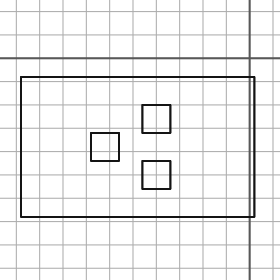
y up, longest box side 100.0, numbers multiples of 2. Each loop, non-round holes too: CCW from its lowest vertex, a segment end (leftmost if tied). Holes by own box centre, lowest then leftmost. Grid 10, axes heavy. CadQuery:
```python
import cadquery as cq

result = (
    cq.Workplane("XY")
    .moveTo(-98.0, -68.0)
    .lineTo(2.0, -68.0)
    .lineTo(2.0, -8.0)
    .lineTo(-98.0, -8.0)
    .close()
    .moveTo(-46.0, -56.0)
    .lineTo(-34.0, -56.0)
    .lineTo(-34.0, -44.0)
    .lineTo(-46.0, -44.0)
    .close()
    .moveTo(-68.0, -44.0)
    .lineTo(-56.0, -44.0)
    .lineTo(-56.0, -32.0)
    .lineTo(-68.0, -32.0)
    .close()
    .moveTo(-46.0, -32.0)
    .lineTo(-34.0, -32.0)
    .lineTo(-34.0, -20.0)
    .lineTo(-46.0, -20.0)
    .close()
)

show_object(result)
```